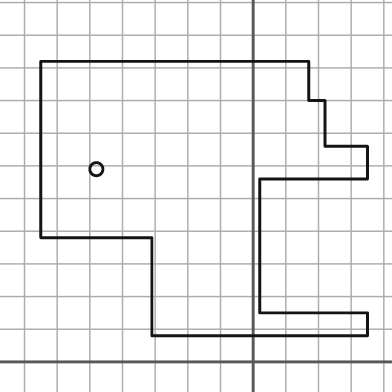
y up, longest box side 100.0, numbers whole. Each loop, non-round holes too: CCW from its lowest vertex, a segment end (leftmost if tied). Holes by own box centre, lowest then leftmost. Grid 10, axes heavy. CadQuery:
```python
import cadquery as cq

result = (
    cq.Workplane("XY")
    .moveTo(-31.0, 8.0)
    .lineTo(35.0, 8.0)
    .lineTo(35.0, 15.0)
    .lineTo(2.0, 15.0)
    .lineTo(2.0, 56.0)
    .lineTo(35.0, 56.0)
    .lineTo(35.0, 66.0)
    .lineTo(22.0, 66.0)
    .lineTo(22.0, 80.0)
    .lineTo(17.0, 80.0)
    .lineTo(17.0, 92.0)
    .lineTo(-65.0, 92.0)
    .lineTo(-65.0, 38.0)
    .lineTo(-31.0, 38.0)
    .close()
    .moveTo(-48.0, 59.0)
    .circle(2.0)
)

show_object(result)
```